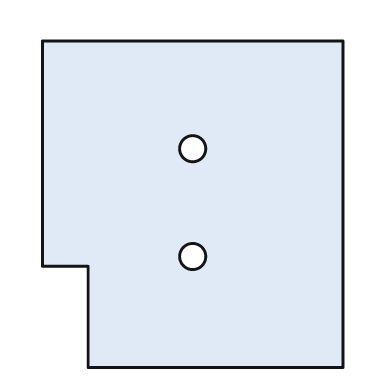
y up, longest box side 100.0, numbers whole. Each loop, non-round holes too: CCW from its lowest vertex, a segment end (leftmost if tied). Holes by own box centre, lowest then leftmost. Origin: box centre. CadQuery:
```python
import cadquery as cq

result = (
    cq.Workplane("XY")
    .moveTo(-32.0, -50.0)
    .lineTo(46.0, -50.0)
    .lineTo(46.0, 50.0)
    .lineTo(-46.0, 50.0)
    .lineTo(-46.0, -19.0)
    .lineTo(-32.0, -19.0)
    .close()
    .moveTo(0.0, -16.0)
    .circle(4.0)
    .moveTo(0.0, 17.0)
    .circle(4.0)
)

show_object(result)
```